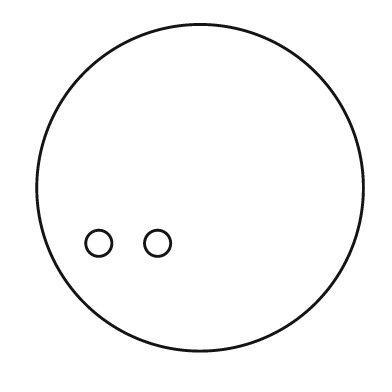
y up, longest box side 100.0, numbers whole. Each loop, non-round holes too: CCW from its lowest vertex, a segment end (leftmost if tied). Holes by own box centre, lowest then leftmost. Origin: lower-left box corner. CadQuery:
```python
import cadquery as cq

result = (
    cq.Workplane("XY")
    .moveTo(50.0, 50.0)
    .circle(50.0)
    .moveTo(19.0, 33.0)
    .circle(4.0)
    .moveTo(37.0, 33.0)
    .circle(4.0)
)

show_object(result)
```